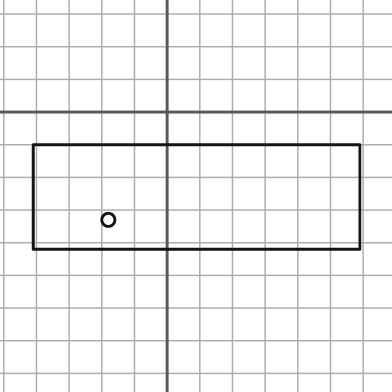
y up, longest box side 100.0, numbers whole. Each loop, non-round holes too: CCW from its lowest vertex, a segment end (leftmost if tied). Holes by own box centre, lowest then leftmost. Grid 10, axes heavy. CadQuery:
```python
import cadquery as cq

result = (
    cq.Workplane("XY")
    .moveTo(-41.0, -42.0)
    .lineTo(59.0, -42.0)
    .lineTo(59.0, -10.0)
    .lineTo(-41.0, -10.0)
    .close()
    .moveTo(-18.0, -33.0)
    .circle(2.0)
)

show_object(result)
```